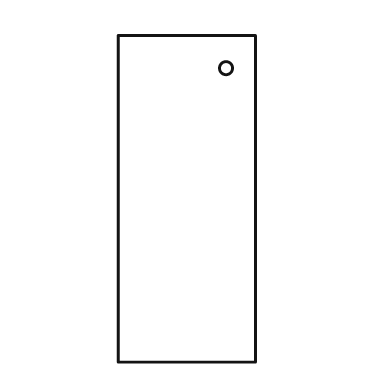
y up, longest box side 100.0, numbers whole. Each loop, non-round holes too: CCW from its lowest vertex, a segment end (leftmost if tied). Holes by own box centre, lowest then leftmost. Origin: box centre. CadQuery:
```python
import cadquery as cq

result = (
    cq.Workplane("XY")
    .moveTo(-21.0, -50.0)
    .lineTo(21.0, -50.0)
    .lineTo(21.0, 50.0)
    .lineTo(-21.0, 50.0)
    .close()
    .moveTo(12.0, 40.0)
    .circle(2.0)
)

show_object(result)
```